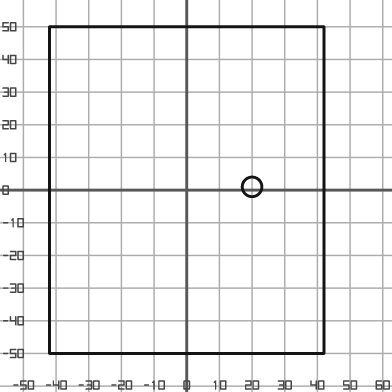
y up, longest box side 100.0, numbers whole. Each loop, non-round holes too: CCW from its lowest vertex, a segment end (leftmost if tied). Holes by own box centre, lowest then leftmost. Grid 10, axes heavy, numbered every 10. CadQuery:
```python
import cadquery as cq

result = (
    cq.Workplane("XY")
    .moveTo(-42.0, -50.0)
    .lineTo(42.0, -50.0)
    .lineTo(42.0, 50.0)
    .lineTo(-42.0, 50.0)
    .close()
    .moveTo(20.0, 1.0)
    .circle(3.0)
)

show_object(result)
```